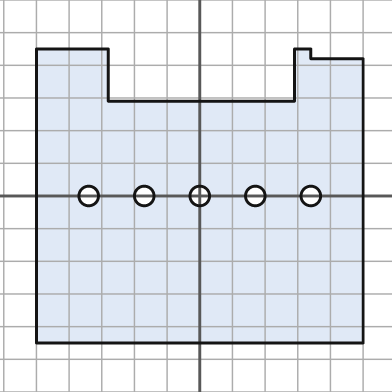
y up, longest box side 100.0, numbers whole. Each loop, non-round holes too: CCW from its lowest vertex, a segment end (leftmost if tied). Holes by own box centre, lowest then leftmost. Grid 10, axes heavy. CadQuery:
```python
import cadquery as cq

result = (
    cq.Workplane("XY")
    .moveTo(-50.0, -45.0)
    .lineTo(50.0, -45.0)
    .lineTo(50.0, 42.0)
    .lineTo(34.0, 42.0)
    .lineTo(34.0, 45.0)
    .lineTo(29.0, 45.0)
    .lineTo(29.0, 29.0)
    .lineTo(-28.0, 29.0)
    .lineTo(-28.0, 45.0)
    .lineTo(-50.0, 45.0)
    .close()
    .moveTo(-34.0, 0.0)
    .circle(3.0)
    .moveTo(-17.0, 0.0)
    .circle(3.0)
    .moveTo(0.0, 0.0)
    .circle(3.0)
    .moveTo(17.0, 0.0)
    .circle(3.0)
    .moveTo(34.0, 0.0)
    .circle(3.0)
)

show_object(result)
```